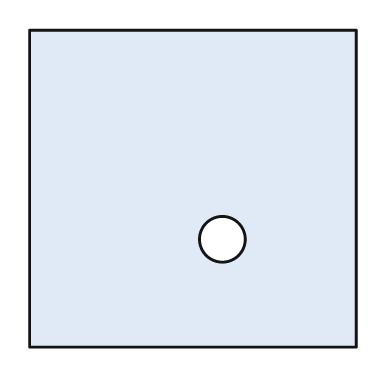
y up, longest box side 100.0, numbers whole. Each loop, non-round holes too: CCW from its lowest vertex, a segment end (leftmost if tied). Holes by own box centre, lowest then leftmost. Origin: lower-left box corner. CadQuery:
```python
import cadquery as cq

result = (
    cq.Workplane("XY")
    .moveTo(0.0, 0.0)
    .lineTo(100.0, 0.0)
    .lineTo(100.0, 97.0)
    .lineTo(0.0, 97.0)
    .close()
    .moveTo(59.0, 33.0)
    .circle(7.0)
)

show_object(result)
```